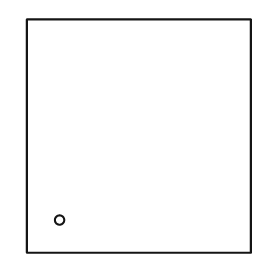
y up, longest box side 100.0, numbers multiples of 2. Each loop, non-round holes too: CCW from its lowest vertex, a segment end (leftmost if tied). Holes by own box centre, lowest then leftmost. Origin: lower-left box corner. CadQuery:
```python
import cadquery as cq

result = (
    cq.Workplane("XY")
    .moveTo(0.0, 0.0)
    .lineTo(96.0, 0.0)
    .lineTo(96.0, 100.0)
    .lineTo(0.0, 100.0)
    .close()
    .moveTo(14.0, 14.0)
    .circle(2.0)
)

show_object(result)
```